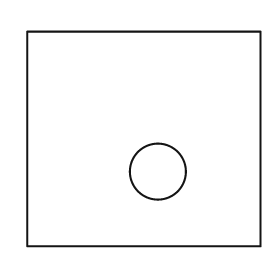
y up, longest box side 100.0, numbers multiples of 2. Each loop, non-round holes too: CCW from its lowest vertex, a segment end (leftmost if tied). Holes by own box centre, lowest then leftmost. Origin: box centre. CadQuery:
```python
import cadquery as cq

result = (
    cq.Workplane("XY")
    .moveTo(-50.0, -46.0)
    .lineTo(50.0, -46.0)
    .lineTo(50.0, 46.0)
    .lineTo(-50.0, 46.0)
    .close()
    .moveTo(6.0, -14.0)
    .circle(12.0)
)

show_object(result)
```